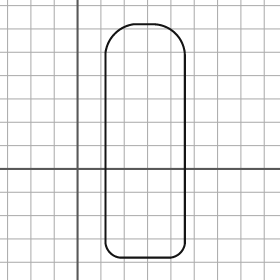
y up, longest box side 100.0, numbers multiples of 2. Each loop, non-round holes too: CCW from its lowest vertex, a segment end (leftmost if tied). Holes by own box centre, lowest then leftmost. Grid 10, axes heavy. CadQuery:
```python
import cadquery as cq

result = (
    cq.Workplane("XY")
    .moveTo(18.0, -38.0)
    .lineTo(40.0, -38.0)
    .threePointArc((44.0, -36.0), (46.0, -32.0))
    .lineTo(46.0, 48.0)
    .threePointArc((42.0, 58.0), (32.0, 62.0))
    .lineTo(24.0, 62.0)
    .threePointArc((16.0, 58.0), (12.0, 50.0))
    .lineTo(12.0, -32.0)
    .threePointArc((14.0, -36.0), (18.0, -38.0))
    .close()
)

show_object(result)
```